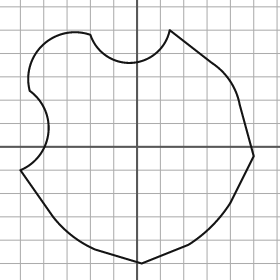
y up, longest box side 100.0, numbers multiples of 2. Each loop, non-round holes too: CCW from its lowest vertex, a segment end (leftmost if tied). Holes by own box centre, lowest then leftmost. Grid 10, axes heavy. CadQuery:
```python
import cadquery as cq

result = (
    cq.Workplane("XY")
    .moveTo(2.0, -50.0)
    .lineTo(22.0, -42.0)
    .threePointArc((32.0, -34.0), (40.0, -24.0))
    .lineTo(50.0, -4.0)
    .lineTo(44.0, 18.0)
    .threePointArc((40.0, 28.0), (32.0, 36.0))
    .lineTo(14.0, 50.0)
    .threePointArc((-2.0, 36.0), (-20.0, 48.0))
    .threePointArc((-40.0, 44.0), (-46.0, 24.0))
    .threePointArc((-38.0, 6.0), (-50.0, -10.0))
    .lineTo(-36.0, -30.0)
    .threePointArc((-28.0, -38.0), (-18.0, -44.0))
    .close()
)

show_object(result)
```